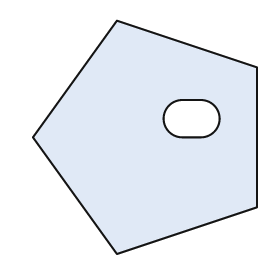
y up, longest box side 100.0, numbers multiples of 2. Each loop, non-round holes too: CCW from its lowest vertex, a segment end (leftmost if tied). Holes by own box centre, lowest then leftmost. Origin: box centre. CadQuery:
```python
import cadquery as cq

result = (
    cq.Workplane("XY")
    .moveTo(-12.0, -50.0)
    .lineTo(48.0, -30.0)
    .lineTo(48.0, 30.0)
    .lineTo(-12.0, 50.0)
    .lineTo(-48.0, 0.0)
    .close()
    .moveTo(16.0, 0.0)
    .lineTo(24.0, 0.0)
    .threePointArc((32.0, 8.0), (24.0, 16.0))
    .lineTo(16.0, 16.0)
    .threePointArc((8.0, 8.0), (16.0, 0.0))
    .close()
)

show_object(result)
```